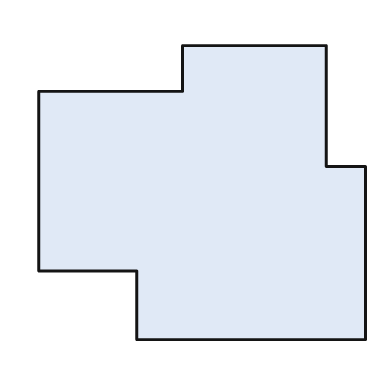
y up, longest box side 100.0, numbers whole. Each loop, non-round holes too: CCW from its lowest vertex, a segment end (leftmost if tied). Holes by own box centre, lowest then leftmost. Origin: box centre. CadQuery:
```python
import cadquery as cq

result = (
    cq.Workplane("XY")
    .moveTo(-20.0, -45.0)
    .lineTo(50.0, -45.0)
    .lineTo(50.0, 8.0)
    .lineTo(38.0, 8.0)
    .lineTo(38.0, 45.0)
    .lineTo(-6.0, 45.0)
    .lineTo(-6.0, 31.0)
    .lineTo(-50.0, 31.0)
    .lineTo(-50.0, -24.0)
    .lineTo(-20.0, -24.0)
    .close()
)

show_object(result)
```